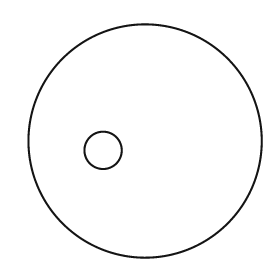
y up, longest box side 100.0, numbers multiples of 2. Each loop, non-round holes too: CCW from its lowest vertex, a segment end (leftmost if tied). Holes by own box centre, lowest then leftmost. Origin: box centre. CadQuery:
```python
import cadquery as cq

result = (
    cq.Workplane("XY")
    .moveTo(0.0, 0.0)
    .circle(50.0)
    .moveTo(-18.0, -4.0)
    .circle(8.0)
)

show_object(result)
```